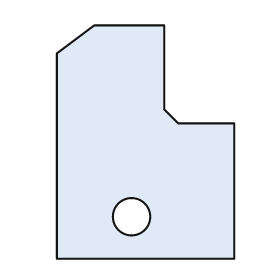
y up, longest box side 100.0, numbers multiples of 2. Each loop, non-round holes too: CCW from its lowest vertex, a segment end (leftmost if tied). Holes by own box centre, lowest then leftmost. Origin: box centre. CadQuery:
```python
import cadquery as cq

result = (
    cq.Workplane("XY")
    .moveTo(-38.0, -50.0)
    .lineTo(38.0, -50.0)
    .lineTo(38.0, 8.0)
    .lineTo(14.0, 8.0)
    .lineTo(8.0, 14.0)
    .lineTo(8.0, 50.0)
    .lineTo(-22.0, 50.0)
    .lineTo(-38.0, 38.0)
    .close()
    .moveTo(-6.0, -32.0)
    .circle(8.0)
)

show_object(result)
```